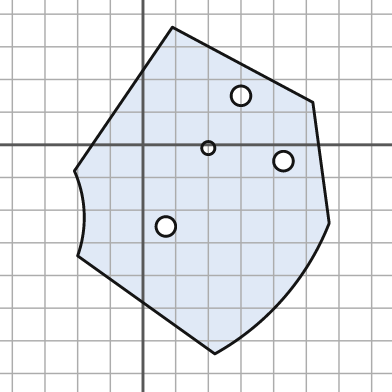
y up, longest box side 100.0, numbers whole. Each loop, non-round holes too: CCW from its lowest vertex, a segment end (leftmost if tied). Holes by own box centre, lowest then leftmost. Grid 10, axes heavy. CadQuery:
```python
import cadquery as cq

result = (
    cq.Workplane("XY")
    .moveTo(22.0, -64.0)
    .threePointArc((43.0, -47.0), (57.0, -24.0))
    .lineTo(52.0, 13.0)
    .lineTo(9.0, 36.0)
    .lineTo(-21.0, -8.0)
    .threePointArc((-18.0, -21.0), (-20.0, -34.0))
    .close()
    .moveTo(7.0, -25.0)
    .circle(3.0)
    .moveTo(43.0, -5.0)
    .circle(3.0)
    .moveTo(20.0, -1.0)
    .circle(2.0)
    .moveTo(30.0, 15.0)
    .circle(3.0)
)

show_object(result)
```